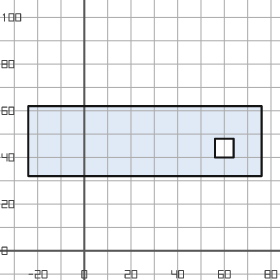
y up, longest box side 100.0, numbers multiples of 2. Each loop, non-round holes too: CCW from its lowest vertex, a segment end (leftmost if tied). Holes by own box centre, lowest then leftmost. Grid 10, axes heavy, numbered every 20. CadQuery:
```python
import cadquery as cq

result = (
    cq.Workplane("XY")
    .moveTo(-24.0, 32.0)
    .lineTo(76.0, 32.0)
    .lineTo(76.0, 62.0)
    .lineTo(-24.0, 62.0)
    .close()
    .moveTo(56.0, 40.0)
    .lineTo(64.0, 40.0)
    .lineTo(64.0, 48.0)
    .lineTo(56.0, 48.0)
    .close()
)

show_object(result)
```